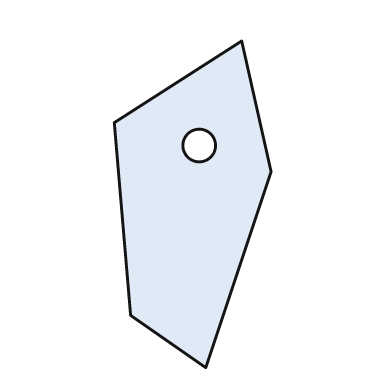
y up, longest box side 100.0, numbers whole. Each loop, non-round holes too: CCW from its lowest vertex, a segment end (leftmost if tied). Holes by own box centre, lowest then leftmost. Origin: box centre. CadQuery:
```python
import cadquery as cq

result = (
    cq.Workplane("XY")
    .moveTo(4.0, -50.0)
    .lineTo(24.0, 10.0)
    .lineTo(15.0, 50.0)
    .lineTo(-24.0, 25.0)
    .lineTo(-19.0, -34.0)
    .close()
    .moveTo(2.0, 18.0)
    .circle(5.0)
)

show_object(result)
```